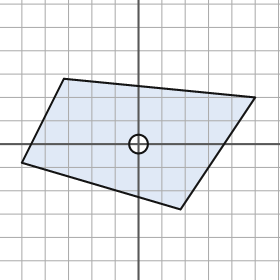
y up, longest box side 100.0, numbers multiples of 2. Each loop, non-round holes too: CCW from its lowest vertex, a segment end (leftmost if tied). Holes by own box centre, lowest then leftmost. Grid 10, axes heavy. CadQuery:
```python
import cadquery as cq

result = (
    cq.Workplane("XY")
    .moveTo(18.0, -28.0)
    .lineTo(50.0, 20.0)
    .lineTo(-32.0, 28.0)
    .lineTo(-50.0, -8.0)
    .close()
    .moveTo(0.0, 0.0)
    .circle(4.0)
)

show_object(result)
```